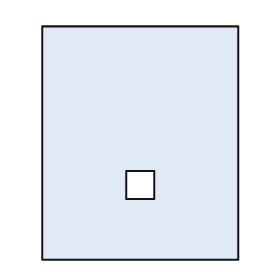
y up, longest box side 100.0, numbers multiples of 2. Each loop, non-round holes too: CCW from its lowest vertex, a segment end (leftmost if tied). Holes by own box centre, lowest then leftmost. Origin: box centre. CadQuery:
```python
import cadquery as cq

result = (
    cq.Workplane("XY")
    .moveTo(-42.0, -50.0)
    .lineTo(42.0, -50.0)
    .lineTo(42.0, 50.0)
    .lineTo(-42.0, 50.0)
    .close()
    .moveTo(-6.0, -24.0)
    .lineTo(6.0, -24.0)
    .lineTo(6.0, -12.0)
    .lineTo(-6.0, -12.0)
    .close()
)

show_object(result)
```